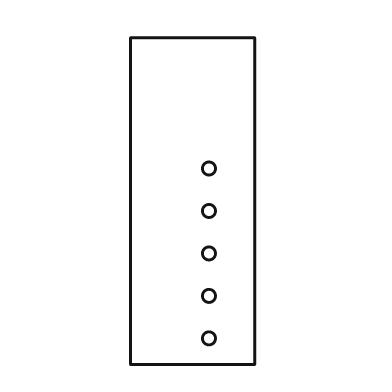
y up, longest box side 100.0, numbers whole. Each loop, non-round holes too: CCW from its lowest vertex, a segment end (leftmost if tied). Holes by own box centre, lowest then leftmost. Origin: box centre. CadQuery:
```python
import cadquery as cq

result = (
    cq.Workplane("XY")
    .moveTo(-19.0, -50.0)
    .lineTo(19.0, -50.0)
    .lineTo(19.0, 50.0)
    .lineTo(-19.0, 50.0)
    .close()
    .moveTo(5.0, -42.0)
    .circle(2.0)
    .moveTo(5.0, -29.0)
    .circle(2.0)
    .moveTo(5.0, -16.0)
    .circle(2.0)
    .moveTo(5.0, -3.0)
    .circle(2.0)
    .moveTo(5.0, 10.0)
    .circle(2.0)
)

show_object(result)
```